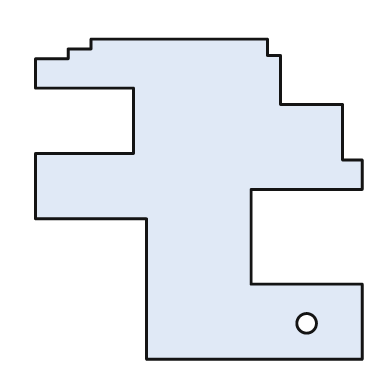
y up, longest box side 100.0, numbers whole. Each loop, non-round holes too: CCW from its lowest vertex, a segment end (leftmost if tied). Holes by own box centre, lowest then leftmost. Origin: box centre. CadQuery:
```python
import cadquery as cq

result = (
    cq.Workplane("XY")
    .moveTo(-16.0, -49.0)
    .lineTo(50.0, -49.0)
    .lineTo(50.0, -26.0)
    .lineTo(16.0, -26.0)
    .lineTo(16.0, 3.0)
    .lineTo(50.0, 3.0)
    .lineTo(50.0, 12.0)
    .lineTo(44.0, 12.0)
    .lineTo(44.0, 29.0)
    .lineTo(25.0, 29.0)
    .lineTo(25.0, 44.0)
    .lineTo(21.0, 44.0)
    .lineTo(21.0, 49.0)
    .lineTo(-33.0, 49.0)
    .lineTo(-33.0, 46.0)
    .lineTo(-40.0, 46.0)
    .lineTo(-40.0, 43.0)
    .lineTo(-50.0, 43.0)
    .lineTo(-50.0, 34.0)
    .lineTo(-20.0, 34.0)
    .lineTo(-20.0, 14.0)
    .lineTo(-50.0, 14.0)
    .lineTo(-50.0, -6.0)
    .lineTo(-16.0, -6.0)
    .close()
    .moveTo(33.0, -38.0)
    .circle(3.0)
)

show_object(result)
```